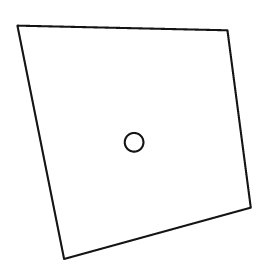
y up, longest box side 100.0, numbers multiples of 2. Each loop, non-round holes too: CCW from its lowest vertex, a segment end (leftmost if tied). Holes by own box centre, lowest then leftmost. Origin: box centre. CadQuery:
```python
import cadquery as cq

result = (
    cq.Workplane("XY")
    .moveTo(-30.0, -50.0)
    .lineTo(50.0, -28.0)
    .lineTo(40.0, 48.0)
    .lineTo(-50.0, 50.0)
    .close()
    .moveTo(0.0, 0.0)
    .circle(4.0)
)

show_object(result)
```